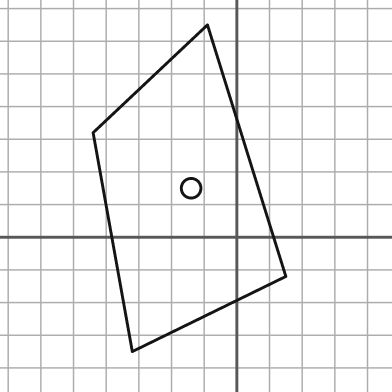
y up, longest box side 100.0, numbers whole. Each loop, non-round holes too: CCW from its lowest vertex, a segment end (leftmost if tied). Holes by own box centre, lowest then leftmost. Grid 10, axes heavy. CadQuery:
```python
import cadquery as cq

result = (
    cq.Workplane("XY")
    .moveTo(-32.0, -35.0)
    .lineTo(15.0, -12.0)
    .lineTo(-9.0, 65.0)
    .lineTo(-44.0, 32.0)
    .close()
    .moveTo(-14.0, 15.0)
    .circle(3.0)
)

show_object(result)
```